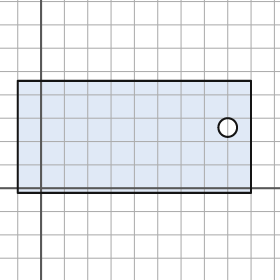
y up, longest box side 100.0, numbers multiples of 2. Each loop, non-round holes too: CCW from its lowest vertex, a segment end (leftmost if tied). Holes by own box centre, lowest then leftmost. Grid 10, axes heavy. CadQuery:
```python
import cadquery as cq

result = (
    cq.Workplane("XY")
    .moveTo(-10.0, -2.0)
    .lineTo(90.0, -2.0)
    .lineTo(90.0, 46.0)
    .lineTo(-10.0, 46.0)
    .close()
    .moveTo(80.0, 26.0)
    .circle(4.0)
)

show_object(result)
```